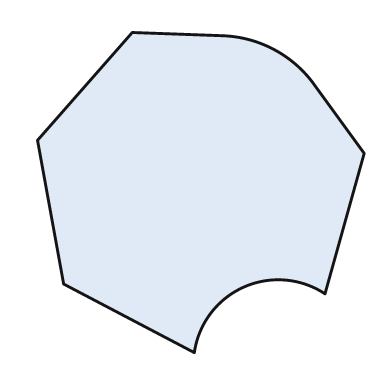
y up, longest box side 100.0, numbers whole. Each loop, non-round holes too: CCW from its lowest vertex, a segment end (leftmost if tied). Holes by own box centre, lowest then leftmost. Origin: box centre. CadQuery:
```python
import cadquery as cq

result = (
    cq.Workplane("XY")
    .moveTo(-2.0, -49.0)
    .threePointArc((13.0, -29.0), (38.0, -31.0))
    .lineTo(50.0, 12.0)
    .lineTo(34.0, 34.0)
    .threePointArc((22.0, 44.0), (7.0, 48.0))
    .lineTo(-21.0, 49.0)
    .lineTo(-50.0, 16.0)
    .lineTo(-42.0, -28.0)
    .close()
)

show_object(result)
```